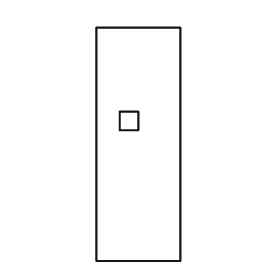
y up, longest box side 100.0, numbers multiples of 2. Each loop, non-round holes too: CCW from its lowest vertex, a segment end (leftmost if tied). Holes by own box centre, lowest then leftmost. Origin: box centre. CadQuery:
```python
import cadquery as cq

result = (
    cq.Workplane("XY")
    .moveTo(-18.0, -50.0)
    .lineTo(18.0, -50.0)
    .lineTo(18.0, 50.0)
    .lineTo(-18.0, 50.0)
    .close()
    .moveTo(-8.0, 6.0)
    .lineTo(0.0, 6.0)
    .lineTo(0.0, 14.0)
    .lineTo(-8.0, 14.0)
    .close()
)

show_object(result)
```